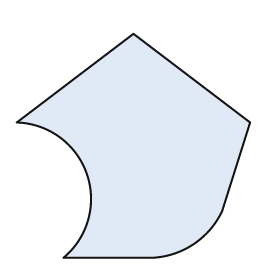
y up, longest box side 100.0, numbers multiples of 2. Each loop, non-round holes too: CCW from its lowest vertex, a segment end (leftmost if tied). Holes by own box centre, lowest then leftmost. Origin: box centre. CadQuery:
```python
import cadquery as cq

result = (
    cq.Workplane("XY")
    .moveTo(-30.0, -48.0)
    .lineTo(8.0, -48.0)
    .threePointArc((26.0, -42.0), (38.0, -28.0))
    .lineTo(50.0, 10.0)
    .lineTo(0.0, 48.0)
    .lineTo(-50.0, 10.0)
    .threePointArc((-20.0, -12.0), (-30.0, -48.0))
    .close()
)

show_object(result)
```